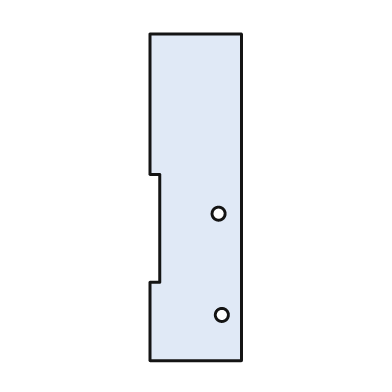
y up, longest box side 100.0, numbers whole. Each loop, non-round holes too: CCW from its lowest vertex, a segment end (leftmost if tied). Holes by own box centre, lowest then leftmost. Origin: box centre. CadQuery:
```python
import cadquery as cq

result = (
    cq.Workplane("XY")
    .moveTo(-14.0, -50.0)
    .lineTo(14.0, -50.0)
    .lineTo(14.0, 50.0)
    .lineTo(-14.0, 50.0)
    .lineTo(-14.0, 7.0)
    .lineTo(-11.0, 7.0)
    .lineTo(-11.0, -26.0)
    .lineTo(-14.0, -26.0)
    .close()
    .moveTo(8.0, -36.0)
    .circle(2.0)
    .moveTo(7.0, -5.0)
    .circle(2.0)
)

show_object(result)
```